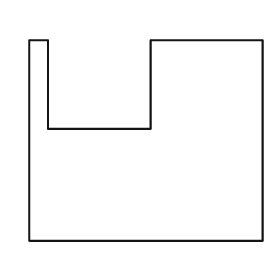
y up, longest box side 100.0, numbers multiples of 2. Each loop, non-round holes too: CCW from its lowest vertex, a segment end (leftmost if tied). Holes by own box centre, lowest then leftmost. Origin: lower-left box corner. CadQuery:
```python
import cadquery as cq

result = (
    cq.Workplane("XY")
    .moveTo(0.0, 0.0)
    .lineTo(100.0, 0.0)
    .lineTo(100.0, 86.0)
    .lineTo(52.0, 86.0)
    .lineTo(52.0, 48.0)
    .lineTo(8.0, 48.0)
    .lineTo(8.0, 86.0)
    .lineTo(0.0, 86.0)
    .close()
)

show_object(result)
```